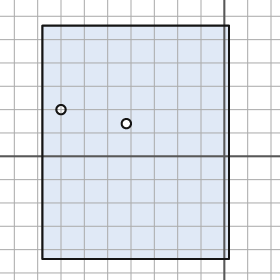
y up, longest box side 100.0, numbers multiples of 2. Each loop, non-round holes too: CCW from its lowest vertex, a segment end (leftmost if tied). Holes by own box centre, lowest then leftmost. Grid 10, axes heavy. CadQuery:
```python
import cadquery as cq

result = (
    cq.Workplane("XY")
    .moveTo(-78.0, -44.0)
    .lineTo(2.0, -44.0)
    .lineTo(2.0, 56.0)
    .lineTo(-78.0, 56.0)
    .close()
    .moveTo(-42.0, 14.0)
    .circle(2.0)
    .moveTo(-70.0, 20.0)
    .circle(2.0)
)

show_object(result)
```